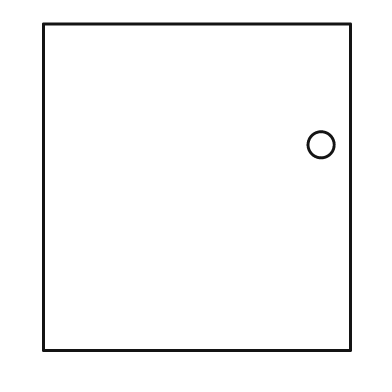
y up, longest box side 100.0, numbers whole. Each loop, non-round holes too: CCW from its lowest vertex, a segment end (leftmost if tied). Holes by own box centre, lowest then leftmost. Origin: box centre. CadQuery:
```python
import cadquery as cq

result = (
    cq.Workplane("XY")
    .moveTo(-47.0, -50.0)
    .lineTo(47.0, -50.0)
    .lineTo(47.0, 50.0)
    .lineTo(-47.0, 50.0)
    .close()
    .moveTo(38.0, 13.0)
    .circle(4.0)
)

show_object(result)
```